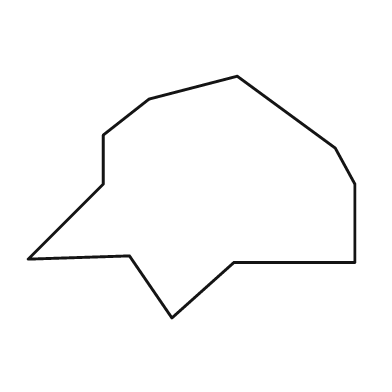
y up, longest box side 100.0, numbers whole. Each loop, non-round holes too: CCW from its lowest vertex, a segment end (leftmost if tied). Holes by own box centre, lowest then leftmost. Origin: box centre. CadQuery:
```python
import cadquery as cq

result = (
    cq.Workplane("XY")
    .moveTo(-6.0, -37.0)
    .lineTo(13.0, -20.0)
    .lineTo(50.0, -20.0)
    .lineTo(50.0, 4.0)
    .lineTo(44.0, 15.0)
    .lineTo(14.0, 37.0)
    .lineTo(-13.0, 30.0)
    .lineTo(-27.0, 19.0)
    .lineTo(-27.0, 4.0)
    .lineTo(-50.0, -19.0)
    .lineTo(-19.0, -18.0)
    .close()
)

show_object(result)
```